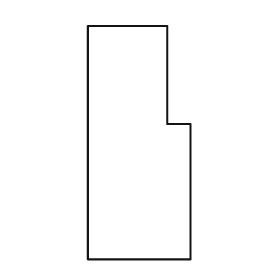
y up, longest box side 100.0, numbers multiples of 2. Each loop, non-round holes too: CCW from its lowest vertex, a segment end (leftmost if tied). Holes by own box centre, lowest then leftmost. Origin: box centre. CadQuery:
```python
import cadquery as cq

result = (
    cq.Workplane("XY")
    .moveTo(-22.0, -50.0)
    .lineTo(22.0, -50.0)
    .lineTo(22.0, 8.0)
    .lineTo(12.0, 8.0)
    .lineTo(12.0, 50.0)
    .lineTo(-22.0, 50.0)
    .close()
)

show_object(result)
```